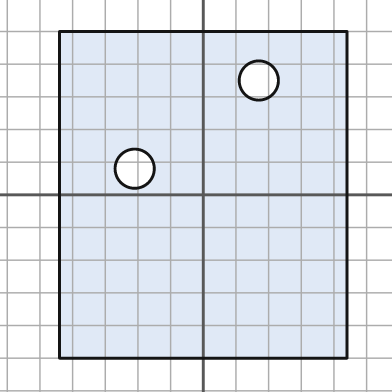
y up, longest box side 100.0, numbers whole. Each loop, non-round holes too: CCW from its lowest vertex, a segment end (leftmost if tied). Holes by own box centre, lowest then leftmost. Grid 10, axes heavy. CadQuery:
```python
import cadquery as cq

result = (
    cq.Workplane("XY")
    .moveTo(-44.0, -50.0)
    .lineTo(44.0, -50.0)
    .lineTo(44.0, 50.0)
    .lineTo(-44.0, 50.0)
    .close()
    .moveTo(-21.0, 8.0)
    .circle(6.0)
    .moveTo(17.0, 35.0)
    .circle(6.0)
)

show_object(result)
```